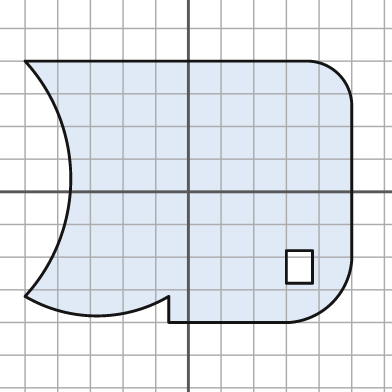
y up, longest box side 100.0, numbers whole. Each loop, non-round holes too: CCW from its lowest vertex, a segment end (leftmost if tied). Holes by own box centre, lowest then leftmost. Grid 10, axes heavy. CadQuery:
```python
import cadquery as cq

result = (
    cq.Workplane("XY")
    .moveTo(-6.0, -40.0)
    .lineTo(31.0, -40.0)
    .threePointArc((44.0, -34.0), (50.0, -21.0))
    .lineTo(50.0, 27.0)
    .threePointArc((46.0, 36.0), (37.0, 40.0))
    .lineTo(-50.0, 40.0)
    .threePointArc((-36.0, 4.0), (-50.0, -32.0))
    .threePointArc((-28.0, -38.0), (-6.0, -32.0))
    .close()
    .moveTo(30.0, -28.0)
    .lineTo(38.0, -28.0)
    .lineTo(38.0, -18.0)
    .lineTo(30.0, -18.0)
    .close()
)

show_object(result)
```